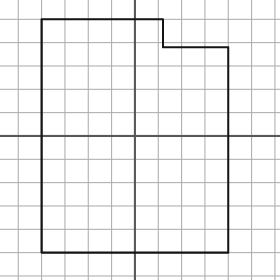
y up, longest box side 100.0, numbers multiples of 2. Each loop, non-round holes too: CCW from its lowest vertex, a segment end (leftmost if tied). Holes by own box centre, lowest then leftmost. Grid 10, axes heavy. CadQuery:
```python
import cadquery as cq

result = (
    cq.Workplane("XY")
    .moveTo(-40.0, -50.0)
    .lineTo(40.0, -50.0)
    .lineTo(40.0, 38.0)
    .lineTo(12.0, 38.0)
    .lineTo(12.0, 50.0)
    .lineTo(-40.0, 50.0)
    .close()
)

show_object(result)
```